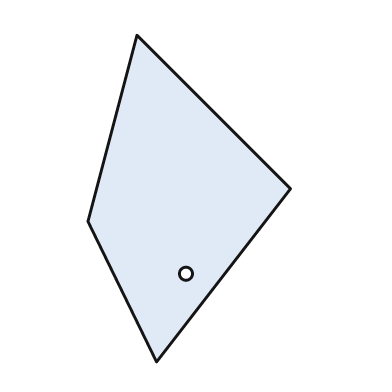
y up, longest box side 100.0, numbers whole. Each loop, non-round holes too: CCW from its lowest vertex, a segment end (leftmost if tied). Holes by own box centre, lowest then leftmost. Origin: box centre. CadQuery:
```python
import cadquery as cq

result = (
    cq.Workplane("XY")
    .moveTo(-10.0, -50.0)
    .lineTo(31.0, 3.0)
    .lineTo(-16.0, 50.0)
    .lineTo(-31.0, -7.0)
    .close()
    .moveTo(-1.0, -23.0)
    .circle(2.0)
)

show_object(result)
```